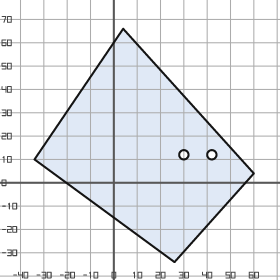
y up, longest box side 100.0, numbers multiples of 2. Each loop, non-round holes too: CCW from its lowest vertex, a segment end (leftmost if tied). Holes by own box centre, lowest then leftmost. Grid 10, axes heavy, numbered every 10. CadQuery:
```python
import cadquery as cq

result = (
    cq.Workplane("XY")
    .moveTo(26.0, -34.0)
    .lineTo(60.0, 4.0)
    .lineTo(4.0, 66.0)
    .lineTo(-34.0, 10.0)
    .close()
    .moveTo(30.0, 12.0)
    .circle(2.0)
    .moveTo(42.0, 12.0)
    .circle(2.0)
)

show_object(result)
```